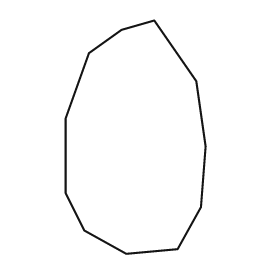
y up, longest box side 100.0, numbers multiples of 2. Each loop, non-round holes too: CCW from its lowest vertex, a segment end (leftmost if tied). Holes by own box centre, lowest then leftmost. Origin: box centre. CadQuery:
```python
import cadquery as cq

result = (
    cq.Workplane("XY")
    .moveTo(-4.0, -50.0)
    .lineTo(18.0, -48.0)
    .lineTo(28.0, -30.0)
    .lineTo(30.0, -4.0)
    .lineTo(26.0, 24.0)
    .lineTo(8.0, 50.0)
    .lineTo(-6.0, 46.0)
    .lineTo(-20.0, 36.0)
    .lineTo(-30.0, 8.0)
    .lineTo(-30.0, -24.0)
    .lineTo(-22.0, -40.0)
    .close()
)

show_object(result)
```